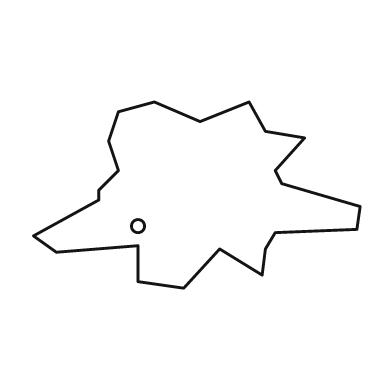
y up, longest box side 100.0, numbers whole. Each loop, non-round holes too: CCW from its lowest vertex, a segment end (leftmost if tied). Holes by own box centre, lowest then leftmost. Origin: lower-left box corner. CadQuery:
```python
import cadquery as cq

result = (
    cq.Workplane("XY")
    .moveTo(46.0, 0.0)
    .lineTo(57.0, 12.0)
    .lineTo(70.0, 4.0)
    .lineTo(71.0, 12.0)
    .lineTo(74.0, 17.0)
    .lineTo(99.0, 18.0)
    .lineTo(100.0, 25.0)
    .lineTo(76.0, 32.0)
    .lineTo(74.0, 36.0)
    .lineTo(83.0, 46.0)
    .lineTo(71.0, 48.0)
    .lineTo(66.0, 57.0)
    .lineTo(51.0, 51.0)
    .lineTo(37.0, 57.0)
    .lineTo(26.0, 54.0)
    .lineTo(23.0, 45.0)
    .lineTo(26.0, 36.0)
    .lineTo(20.0, 30.0)
    .lineTo(20.0, 27.0)
    .lineTo(0.0, 16.0)
    .lineTo(7.0, 11.0)
    .lineTo(32.0, 13.0)
    .lineTo(32.0, 2.0)
    .close()
    .moveTo(32.0, 19.0)
    .circle(2.0)
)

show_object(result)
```